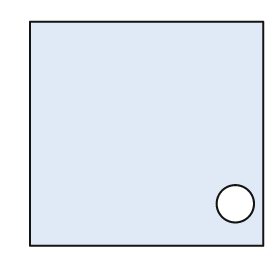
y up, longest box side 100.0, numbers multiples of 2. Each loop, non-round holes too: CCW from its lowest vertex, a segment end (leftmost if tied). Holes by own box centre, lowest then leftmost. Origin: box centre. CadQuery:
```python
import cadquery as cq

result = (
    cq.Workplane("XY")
    .moveTo(-50.0, -48.0)
    .lineTo(50.0, -48.0)
    .lineTo(50.0, 48.0)
    .lineTo(-50.0, 48.0)
    .close()
    .moveTo(38.0, -30.0)
    .circle(8.0)
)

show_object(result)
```